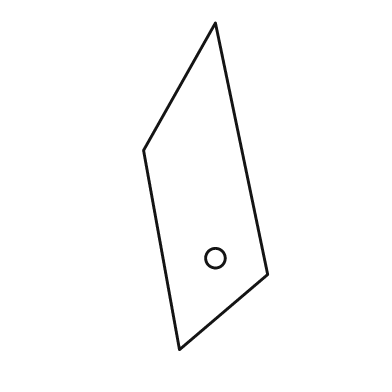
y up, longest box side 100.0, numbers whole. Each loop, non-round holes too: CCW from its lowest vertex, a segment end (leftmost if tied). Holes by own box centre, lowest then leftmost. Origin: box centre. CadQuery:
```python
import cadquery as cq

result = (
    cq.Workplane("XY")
    .moveTo(-8.0, -50.0)
    .lineTo(19.0, -27.0)
    .lineTo(3.0, 50.0)
    .lineTo(-19.0, 11.0)
    .close()
    .moveTo(3.0, -22.0)
    .circle(3.0)
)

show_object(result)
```